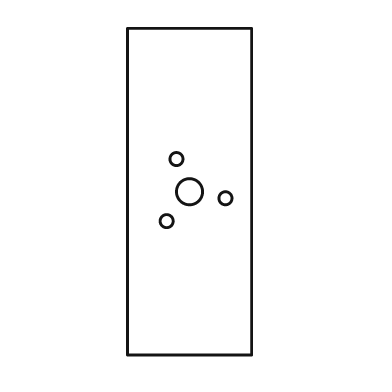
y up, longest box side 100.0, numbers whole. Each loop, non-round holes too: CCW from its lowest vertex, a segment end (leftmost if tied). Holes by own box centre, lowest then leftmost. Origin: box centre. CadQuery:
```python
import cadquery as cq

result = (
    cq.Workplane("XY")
    .moveTo(-19.0, -50.0)
    .lineTo(19.0, -50.0)
    .lineTo(19.0, 50.0)
    .lineTo(-19.0, 50.0)
    .close()
    .moveTo(-7.0, -9.0)
    .circle(2.0)
    .moveTo(11.0, -2.0)
    .circle(2.0)
    .moveTo(0.0, 0.0)
    .circle(4.0)
    .moveTo(-4.0, 10.0)
    .circle(2.0)
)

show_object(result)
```